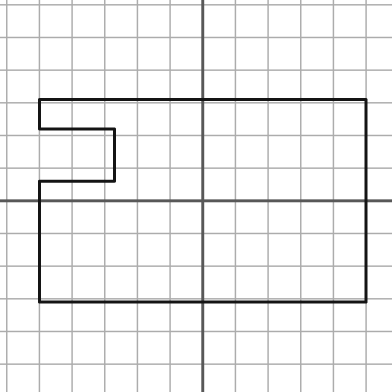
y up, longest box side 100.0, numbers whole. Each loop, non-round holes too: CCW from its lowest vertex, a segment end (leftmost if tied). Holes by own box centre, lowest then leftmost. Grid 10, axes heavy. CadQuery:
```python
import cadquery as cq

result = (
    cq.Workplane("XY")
    .moveTo(-50.0, -31.0)
    .lineTo(50.0, -31.0)
    .lineTo(50.0, 31.0)
    .lineTo(-50.0, 31.0)
    .lineTo(-50.0, 22.0)
    .lineTo(-27.0, 22.0)
    .lineTo(-27.0, 6.0)
    .lineTo(-50.0, 6.0)
    .close()
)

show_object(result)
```